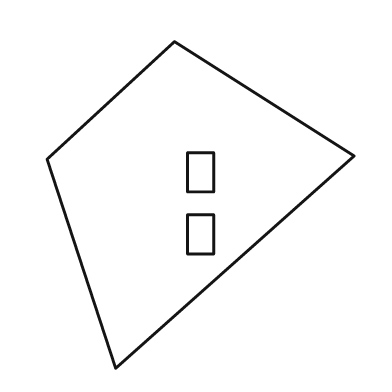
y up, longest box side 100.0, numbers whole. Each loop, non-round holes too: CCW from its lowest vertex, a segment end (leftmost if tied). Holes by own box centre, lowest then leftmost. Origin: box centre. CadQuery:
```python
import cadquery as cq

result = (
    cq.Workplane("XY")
    .moveTo(-26.0, -50.0)
    .lineTo(47.0, 15.0)
    .lineTo(-8.0, 50.0)
    .lineTo(-47.0, 14.0)
    .close()
    .moveTo(-4.0, -15.0)
    .lineTo(4.0, -15.0)
    .lineTo(4.0, -3.0)
    .lineTo(-4.0, -3.0)
    .close()
    .moveTo(-4.0, 4.0)
    .lineTo(4.0, 4.0)
    .lineTo(4.0, 16.0)
    .lineTo(-4.0, 16.0)
    .close()
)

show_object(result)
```